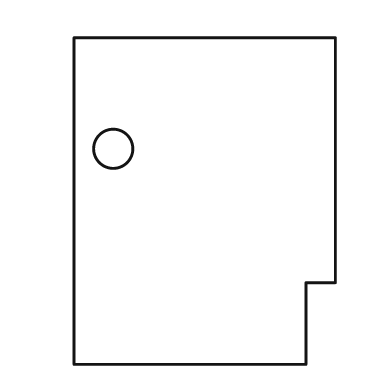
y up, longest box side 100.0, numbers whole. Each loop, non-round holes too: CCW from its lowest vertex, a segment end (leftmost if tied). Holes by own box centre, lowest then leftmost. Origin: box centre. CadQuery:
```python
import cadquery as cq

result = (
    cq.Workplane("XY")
    .moveTo(-40.0, -50.0)
    .lineTo(31.0, -50.0)
    .lineTo(31.0, -25.0)
    .lineTo(40.0, -25.0)
    .lineTo(40.0, 50.0)
    .lineTo(-40.0, 50.0)
    .close()
    .moveTo(-28.0, 16.0)
    .circle(6.0)
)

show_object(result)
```